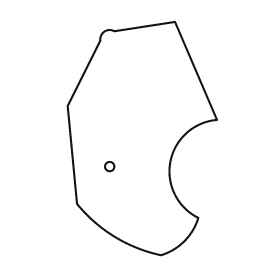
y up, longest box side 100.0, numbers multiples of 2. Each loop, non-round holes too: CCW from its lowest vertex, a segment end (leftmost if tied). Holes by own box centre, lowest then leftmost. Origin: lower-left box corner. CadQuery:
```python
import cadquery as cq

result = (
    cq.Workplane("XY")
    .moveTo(40.0, 0.0)
    .threePointArc((50.0, 6.0), (56.0, 16.0))
    .threePointArc((44.0, 40.0), (64.0, 58.0))
    .lineTo(46.0, 100.0)
    .lineTo(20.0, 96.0)
    .threePointArc((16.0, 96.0), (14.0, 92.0))
    .lineTo(0.0, 64.0)
    .lineTo(4.0, 22.0)
    .threePointArc((20.0, 8.0), (40.0, 0.0))
    .close()
    .moveTo(18.0, 38.0)
    .circle(2.0)
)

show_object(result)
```